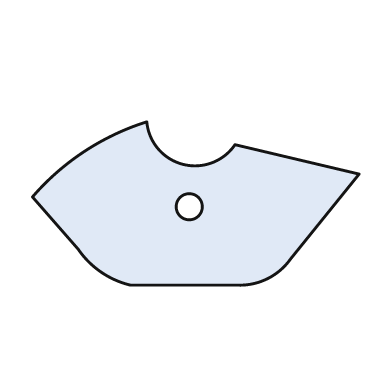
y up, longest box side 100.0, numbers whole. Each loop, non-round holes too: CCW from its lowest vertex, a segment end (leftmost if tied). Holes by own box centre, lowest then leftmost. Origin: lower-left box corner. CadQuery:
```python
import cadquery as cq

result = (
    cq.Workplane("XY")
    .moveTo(30.0, 0.0)
    .lineTo(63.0, 0.0)
    .threePointArc((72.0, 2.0), (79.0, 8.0))
    .lineTo(100.0, 34.0)
    .lineTo(62.0, 43.0)
    .threePointArc((46.0, 37.0), (35.0, 50.0))
    .threePointArc((16.0, 41.0), (0.0, 27.0))
    .lineTo(14.0, 11.0)
    .threePointArc((21.0, 4.0), (30.0, 0.0))
    .close()
    .moveTo(48.0, 24.0)
    .circle(4.0)
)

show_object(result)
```